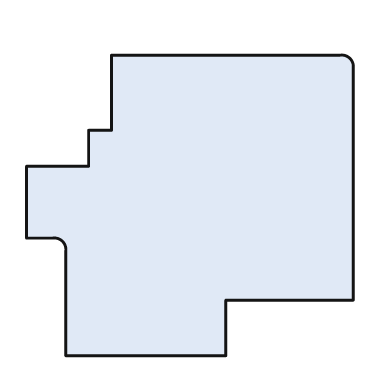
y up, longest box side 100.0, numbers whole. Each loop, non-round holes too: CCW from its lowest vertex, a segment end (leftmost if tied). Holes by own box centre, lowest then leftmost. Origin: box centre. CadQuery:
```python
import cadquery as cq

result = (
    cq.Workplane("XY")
    .moveTo(-38.0, -46.0)
    .lineTo(11.0, -46.0)
    .lineTo(11.0, -29.0)
    .lineTo(50.0, -29.0)
    .lineTo(50.0, 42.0)
    .threePointArc((49.0, 45.0), (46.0, 46.0))
    .lineTo(-24.0, 46.0)
    .lineTo(-24.0, 23.0)
    .lineTo(-31.0, 23.0)
    .lineTo(-31.0, 12.0)
    .lineTo(-50.0, 12.0)
    .lineTo(-50.0, -10.0)
    .lineTo(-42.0, -10.0)
    .threePointArc((-39.0, -11.0), (-38.0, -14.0))
    .close()
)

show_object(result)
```